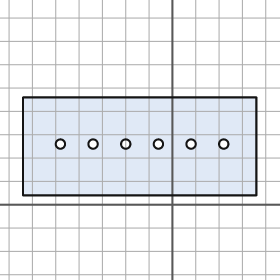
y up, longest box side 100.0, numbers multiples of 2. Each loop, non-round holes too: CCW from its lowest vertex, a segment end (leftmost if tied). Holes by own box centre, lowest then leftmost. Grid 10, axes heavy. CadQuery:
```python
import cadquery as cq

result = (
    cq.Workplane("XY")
    .moveTo(-64.0, 4.0)
    .lineTo(36.0, 4.0)
    .lineTo(36.0, 46.0)
    .lineTo(-64.0, 46.0)
    .close()
    .moveTo(-48.0, 26.0)
    .circle(2.0)
    .moveTo(-34.0, 26.0)
    .circle(2.0)
    .moveTo(-20.0, 26.0)
    .circle(2.0)
    .moveTo(-6.0, 26.0)
    .circle(2.0)
    .moveTo(8.0, 26.0)
    .circle(2.0)
    .moveTo(22.0, 26.0)
    .circle(2.0)
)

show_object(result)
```